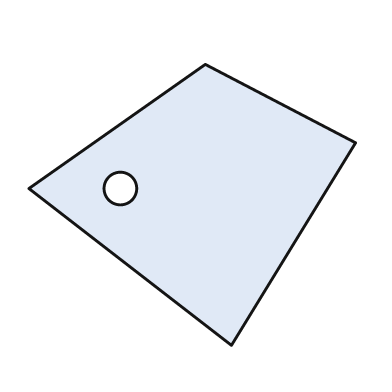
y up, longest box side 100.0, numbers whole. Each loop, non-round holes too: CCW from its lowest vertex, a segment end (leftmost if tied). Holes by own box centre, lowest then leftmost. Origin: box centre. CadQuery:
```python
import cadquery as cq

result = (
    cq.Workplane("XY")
    .moveTo(12.0, -43.0)
    .lineTo(50.0, 19.0)
    .lineTo(4.0, 43.0)
    .lineTo(-50.0, 5.0)
    .close()
    .moveTo(-22.0, 5.0)
    .circle(5.0)
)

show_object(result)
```